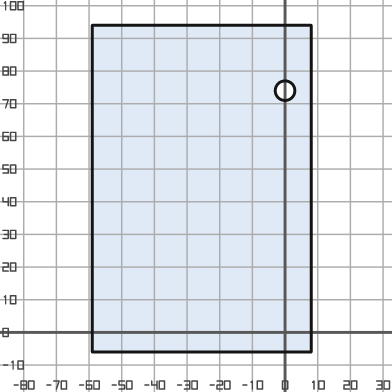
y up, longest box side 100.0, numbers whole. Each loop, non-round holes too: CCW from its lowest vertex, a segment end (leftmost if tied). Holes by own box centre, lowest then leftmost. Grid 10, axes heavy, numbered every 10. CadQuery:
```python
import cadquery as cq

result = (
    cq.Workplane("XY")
    .moveTo(-59.0, -6.0)
    .lineTo(8.0, -6.0)
    .lineTo(8.0, 94.0)
    .lineTo(-59.0, 94.0)
    .close()
    .moveTo(0.0, 74.0)
    .circle(3.0)
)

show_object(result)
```